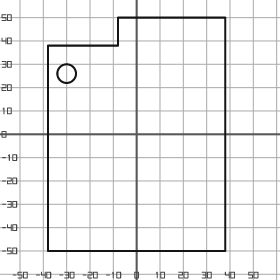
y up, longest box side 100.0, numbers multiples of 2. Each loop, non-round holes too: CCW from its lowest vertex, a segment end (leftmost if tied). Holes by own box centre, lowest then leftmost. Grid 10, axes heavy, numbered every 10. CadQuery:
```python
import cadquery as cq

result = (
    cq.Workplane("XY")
    .moveTo(-38.0, -50.0)
    .lineTo(38.0, -50.0)
    .lineTo(38.0, 50.0)
    .lineTo(-8.0, 50.0)
    .lineTo(-8.0, 38.0)
    .lineTo(-38.0, 38.0)
    .close()
    .moveTo(-30.0, 26.0)
    .circle(4.0)
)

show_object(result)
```